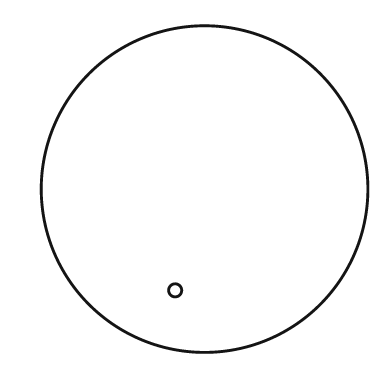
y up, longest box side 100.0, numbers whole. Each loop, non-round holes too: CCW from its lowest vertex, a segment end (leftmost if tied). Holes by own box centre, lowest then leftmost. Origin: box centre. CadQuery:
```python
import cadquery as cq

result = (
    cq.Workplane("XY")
    .moveTo(0.0, 0.0)
    .circle(50.0)
    .moveTo(-9.0, -31.0)
    .circle(2.0)
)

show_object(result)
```